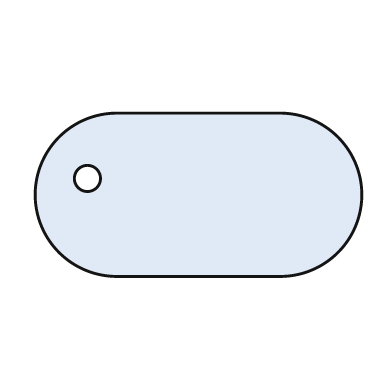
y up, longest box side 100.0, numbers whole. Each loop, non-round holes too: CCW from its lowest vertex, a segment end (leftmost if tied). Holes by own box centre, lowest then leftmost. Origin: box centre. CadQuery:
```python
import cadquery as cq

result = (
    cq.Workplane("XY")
    .moveTo(-25.0, -25.0)
    .lineTo(25.0, -25.0)
    .threePointArc((50.0, 0.0), (25.0, 25.0))
    .lineTo(-25.0, 25.0)
    .threePointArc((-50.0, 0.0), (-25.0, -25.0))
    .close()
    .moveTo(-34.0, 5.0)
    .circle(4.0)
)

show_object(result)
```